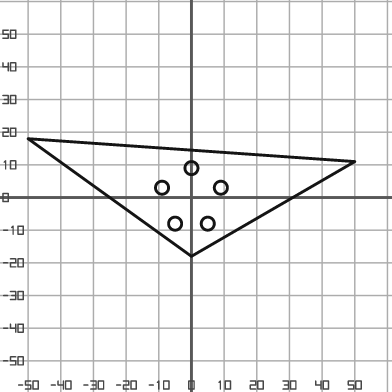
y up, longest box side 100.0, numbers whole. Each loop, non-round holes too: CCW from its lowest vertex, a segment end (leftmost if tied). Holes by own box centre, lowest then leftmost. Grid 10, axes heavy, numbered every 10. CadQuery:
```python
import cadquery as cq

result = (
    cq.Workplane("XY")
    .moveTo(0.0, -18.0)
    .lineTo(50.0, 11.0)
    .lineTo(-50.0, 18.0)
    .close()
    .moveTo(-5.0, -8.0)
    .circle(2.0)
    .moveTo(5.0, -8.0)
    .circle(2.0)
    .moveTo(-9.0, 3.0)
    .circle(2.0)
    .moveTo(9.0, 3.0)
    .circle(2.0)
    .moveTo(0.0, 9.0)
    .circle(2.0)
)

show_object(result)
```